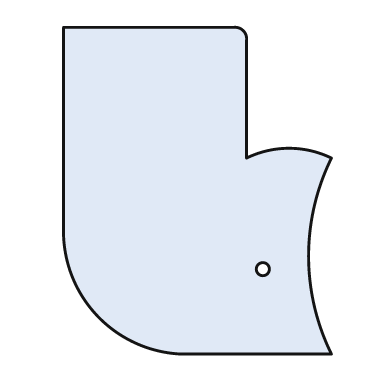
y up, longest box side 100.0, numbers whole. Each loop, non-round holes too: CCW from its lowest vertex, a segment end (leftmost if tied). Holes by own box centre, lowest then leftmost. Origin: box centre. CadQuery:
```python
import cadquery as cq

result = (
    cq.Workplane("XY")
    .moveTo(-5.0, -50.0)
    .lineTo(41.0, -50.0)
    .threePointArc((34.0, -20.0), (41.0, 10.0))
    .threePointArc((28.0, 13.0), (15.0, 10.0))
    .lineTo(15.0, 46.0)
    .threePointArc((14.0, 49.0), (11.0, 50.0))
    .lineTo(-41.0, 50.0)
    .lineTo(-41.0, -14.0)
    .threePointArc((-30.0, -39.0), (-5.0, -50.0))
    .close()
    .moveTo(20.0, -24.0)
    .circle(2.0)
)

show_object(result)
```